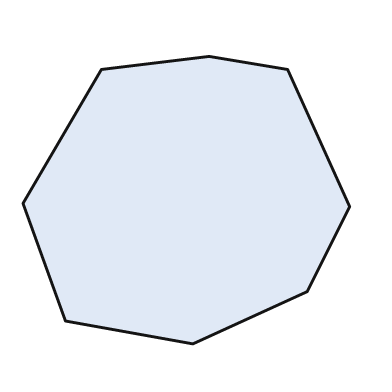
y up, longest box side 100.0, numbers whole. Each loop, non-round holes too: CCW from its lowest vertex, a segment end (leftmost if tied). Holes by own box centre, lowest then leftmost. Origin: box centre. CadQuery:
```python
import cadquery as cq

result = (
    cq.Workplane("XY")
    .moveTo(2.0, -44.0)
    .lineTo(37.0, -28.0)
    .lineTo(50.0, -2.0)
    .lineTo(31.0, 40.0)
    .lineTo(7.0, 44.0)
    .lineTo(-26.0, 40.0)
    .lineTo(-50.0, -1.0)
    .lineTo(-37.0, -37.0)
    .close()
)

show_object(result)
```